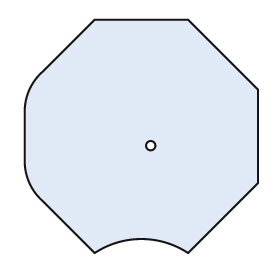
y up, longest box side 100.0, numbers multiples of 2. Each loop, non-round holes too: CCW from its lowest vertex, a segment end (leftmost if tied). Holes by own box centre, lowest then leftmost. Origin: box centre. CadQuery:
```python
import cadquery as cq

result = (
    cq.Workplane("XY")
    .moveTo(-20.0, -50.0)
    .threePointArc((0.0, -44.0), (20.0, -50.0))
    .lineTo(50.0, -20.0)
    .lineTo(50.0, 20.0)
    .lineTo(20.0, 50.0)
    .lineTo(-20.0, 50.0)
    .lineTo(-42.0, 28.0)
    .threePointArc((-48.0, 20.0), (-50.0, 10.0))
    .lineTo(-50.0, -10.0)
    .threePointArc((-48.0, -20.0), (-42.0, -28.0))
    .close()
    .moveTo(4.0, -4.0)
    .circle(2.0)
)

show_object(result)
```